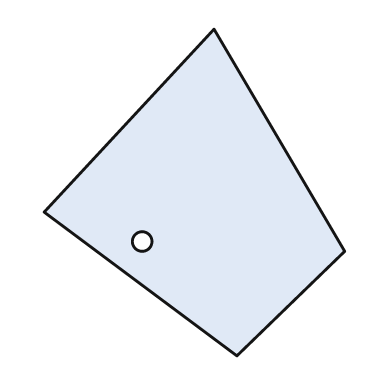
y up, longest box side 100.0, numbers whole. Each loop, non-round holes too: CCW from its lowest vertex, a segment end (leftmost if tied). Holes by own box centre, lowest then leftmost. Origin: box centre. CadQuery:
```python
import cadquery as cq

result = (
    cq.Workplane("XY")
    .moveTo(13.0, -50.0)
    .lineTo(46.0, -18.0)
    .lineTo(6.0, 50.0)
    .lineTo(-46.0, -6.0)
    .close()
    .moveTo(-16.0, -15.0)
    .circle(3.0)
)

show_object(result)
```